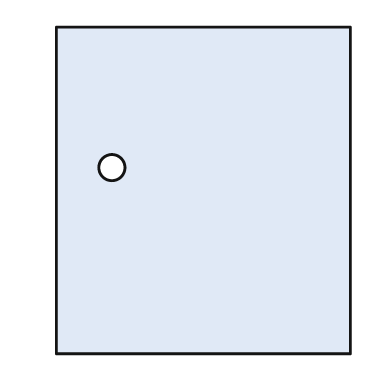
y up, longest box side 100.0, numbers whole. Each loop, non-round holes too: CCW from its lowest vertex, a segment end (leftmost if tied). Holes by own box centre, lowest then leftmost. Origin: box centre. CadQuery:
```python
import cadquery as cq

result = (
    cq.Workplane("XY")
    .moveTo(-45.0, -50.0)
    .lineTo(45.0, -50.0)
    .lineTo(45.0, 50.0)
    .lineTo(-45.0, 50.0)
    .close()
    .moveTo(-28.0, 7.0)
    .circle(4.0)
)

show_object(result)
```